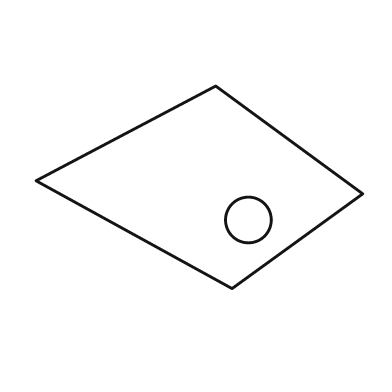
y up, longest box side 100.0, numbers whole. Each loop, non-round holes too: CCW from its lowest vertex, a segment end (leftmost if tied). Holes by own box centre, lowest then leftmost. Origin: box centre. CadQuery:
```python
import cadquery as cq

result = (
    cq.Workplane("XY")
    .moveTo(10.0, -31.0)
    .lineTo(50.0, -2.0)
    .lineTo(5.0, 31.0)
    .lineTo(-50.0, 2.0)
    .close()
    .moveTo(15.0, -10.0)
    .circle(7.0)
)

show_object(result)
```